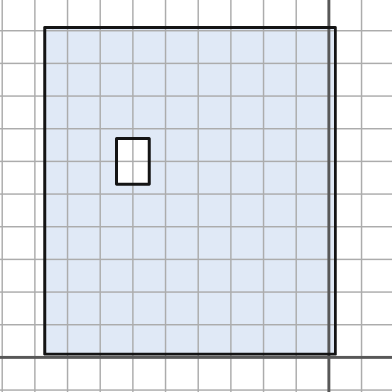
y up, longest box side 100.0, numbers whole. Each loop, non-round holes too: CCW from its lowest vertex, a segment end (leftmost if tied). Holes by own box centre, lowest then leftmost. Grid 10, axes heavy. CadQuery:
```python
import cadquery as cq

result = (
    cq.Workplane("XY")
    .moveTo(-87.0, 1.0)
    .lineTo(2.0, 1.0)
    .lineTo(2.0, 101.0)
    .lineTo(-87.0, 101.0)
    .close()
    .moveTo(-65.0, 53.0)
    .lineTo(-55.0, 53.0)
    .lineTo(-55.0, 67.0)
    .lineTo(-65.0, 67.0)
    .close()
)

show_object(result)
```